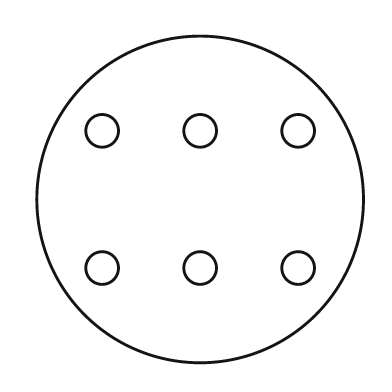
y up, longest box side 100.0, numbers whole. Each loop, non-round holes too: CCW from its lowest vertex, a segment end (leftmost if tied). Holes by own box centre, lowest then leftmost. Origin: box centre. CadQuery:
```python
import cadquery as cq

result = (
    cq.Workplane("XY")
    .moveTo(0.0, 0.0)
    .circle(50.0)
    .moveTo(-30.0, -21.0)
    .circle(5.0)
    .moveTo(0.0, -21.0)
    .circle(5.0)
    .moveTo(30.0, -21.0)
    .circle(5.0)
    .moveTo(-30.0, 21.0)
    .circle(5.0)
    .moveTo(0.0, 21.0)
    .circle(5.0)
    .moveTo(30.0, 21.0)
    .circle(5.0)
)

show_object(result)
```